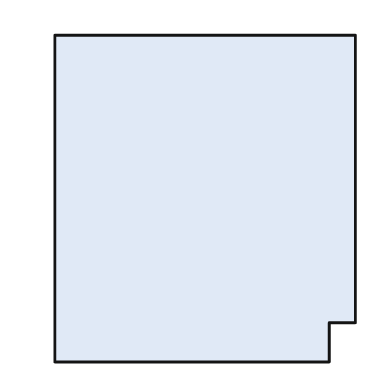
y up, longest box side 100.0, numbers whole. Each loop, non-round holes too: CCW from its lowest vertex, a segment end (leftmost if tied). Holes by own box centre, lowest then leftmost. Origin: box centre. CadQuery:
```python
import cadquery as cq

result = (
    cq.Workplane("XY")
    .moveTo(-46.0, -50.0)
    .lineTo(38.0, -50.0)
    .lineTo(38.0, -38.0)
    .lineTo(46.0, -38.0)
    .lineTo(46.0, 50.0)
    .lineTo(-46.0, 50.0)
    .close()
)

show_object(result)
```